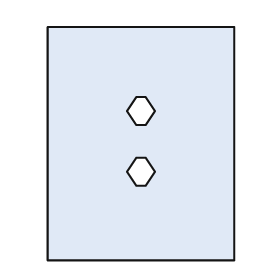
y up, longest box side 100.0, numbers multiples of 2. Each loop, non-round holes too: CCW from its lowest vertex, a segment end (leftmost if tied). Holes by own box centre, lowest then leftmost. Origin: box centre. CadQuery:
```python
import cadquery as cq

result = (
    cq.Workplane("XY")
    .moveTo(-40.0, -50.0)
    .lineTo(40.0, -50.0)
    .lineTo(40.0, 50.0)
    .lineTo(-40.0, 50.0)
    .close()
    .moveTo(-2.0, -18.0)
    .lineTo(2.0, -18.0)
    .lineTo(6.0, -12.0)
    .lineTo(2.0, -6.0)
    .lineTo(-2.0, -6.0)
    .lineTo(-6.0, -12.0)
    .close()
    .moveTo(-2.0, 8.0)
    .lineTo(2.0, 8.0)
    .lineTo(6.0, 14.0)
    .lineTo(2.0, 20.0)
    .lineTo(-2.0, 20.0)
    .lineTo(-6.0, 14.0)
    .close()
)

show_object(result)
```